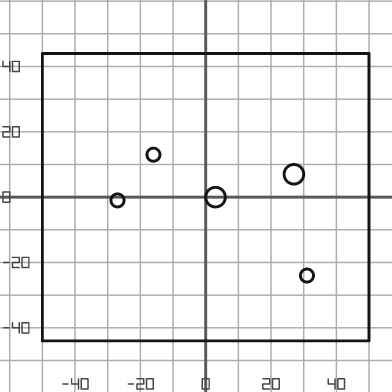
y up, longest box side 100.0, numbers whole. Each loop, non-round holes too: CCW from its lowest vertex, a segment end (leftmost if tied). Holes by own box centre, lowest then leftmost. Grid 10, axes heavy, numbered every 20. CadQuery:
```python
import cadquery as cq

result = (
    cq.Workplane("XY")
    .moveTo(-50.0, -44.0)
    .lineTo(50.0, -44.0)
    .lineTo(50.0, 44.0)
    .lineTo(-50.0, 44.0)
    .close()
    .moveTo(31.0, -24.0)
    .circle(2.0)
    .moveTo(-27.0, -1.0)
    .circle(2.0)
    .moveTo(3.0, 0.0)
    .circle(3.0)
    .moveTo(27.0, 7.0)
    .circle(3.0)
    .moveTo(-16.0, 13.0)
    .circle(2.0)
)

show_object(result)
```